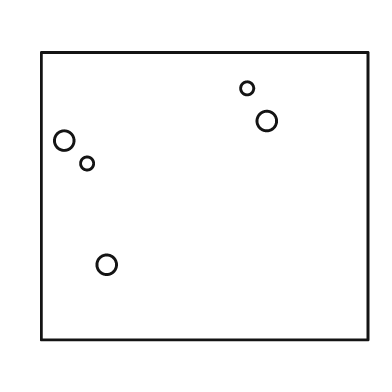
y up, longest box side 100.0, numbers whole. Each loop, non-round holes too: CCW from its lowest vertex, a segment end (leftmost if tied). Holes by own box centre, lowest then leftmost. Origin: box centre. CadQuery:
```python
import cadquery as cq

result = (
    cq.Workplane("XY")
    .moveTo(-50.0, -44.0)
    .lineTo(50.0, -44.0)
    .lineTo(50.0, 44.0)
    .lineTo(-50.0, 44.0)
    .close()
    .moveTo(-30.0, -21.0)
    .circle(3.0)
    .moveTo(-36.0, 10.0)
    .circle(2.0)
    .moveTo(-43.0, 17.0)
    .circle(3.0)
    .moveTo(19.0, 23.0)
    .circle(3.0)
    .moveTo(13.0, 33.0)
    .circle(2.0)
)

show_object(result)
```